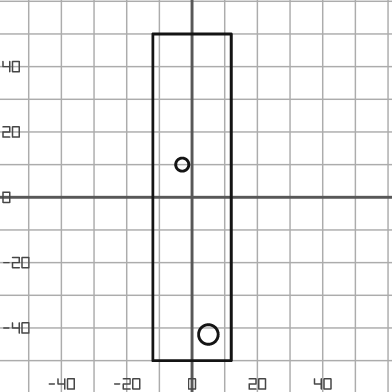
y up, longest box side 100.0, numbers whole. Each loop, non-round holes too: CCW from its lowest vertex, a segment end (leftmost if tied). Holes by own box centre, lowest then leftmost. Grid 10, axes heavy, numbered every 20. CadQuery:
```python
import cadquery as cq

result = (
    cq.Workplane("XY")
    .moveTo(-12.0, -50.0)
    .lineTo(12.0, -50.0)
    .lineTo(12.0, 50.0)
    .lineTo(-12.0, 50.0)
    .close()
    .moveTo(5.0, -42.0)
    .circle(3.0)
    .moveTo(-3.0, 10.0)
    .circle(2.0)
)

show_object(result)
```